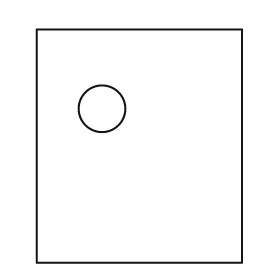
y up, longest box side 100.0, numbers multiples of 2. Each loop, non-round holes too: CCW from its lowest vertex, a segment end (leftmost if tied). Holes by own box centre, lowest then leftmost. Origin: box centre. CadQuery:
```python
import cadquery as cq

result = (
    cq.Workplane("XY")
    .moveTo(-44.0, -50.0)
    .lineTo(44.0, -50.0)
    .lineTo(44.0, 50.0)
    .lineTo(-44.0, 50.0)
    .close()
    .moveTo(-16.0, 16.0)
    .circle(10.0)
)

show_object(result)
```